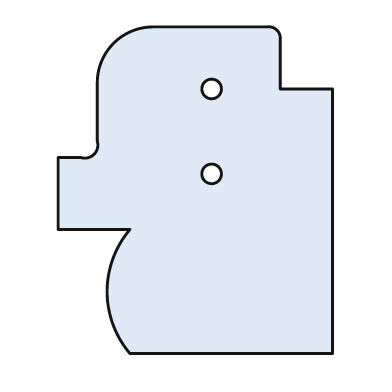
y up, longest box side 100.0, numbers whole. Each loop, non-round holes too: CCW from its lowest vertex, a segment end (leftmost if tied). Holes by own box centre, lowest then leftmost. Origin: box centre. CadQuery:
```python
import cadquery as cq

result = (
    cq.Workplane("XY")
    .moveTo(-20.0, -50.0)
    .lineTo(42.0, -50.0)
    .lineTo(42.0, 31.0)
    .lineTo(26.0, 31.0)
    .lineTo(26.0, 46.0)
    .threePointArc((25.0, 49.0), (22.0, 50.0))
    .lineTo(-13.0, 50.0)
    .threePointArc((-25.0, 45.0), (-30.0, 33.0))
    .lineTo(-30.0, 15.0)
    .threePointArc((-31.0, 11.0), (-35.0, 10.0))
    .lineTo(-42.0, 10.0)
    .lineTo(-42.0, -12.0)
    .lineTo(-20.0, -12.0)
    .threePointArc((-27.0, -31.0), (-20.0, -50.0))
    .close()
    .moveTo(5.0, 5.0)
    .circle(3.0)
    .moveTo(5.0, 31.0)
    .circle(3.0)
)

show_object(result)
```